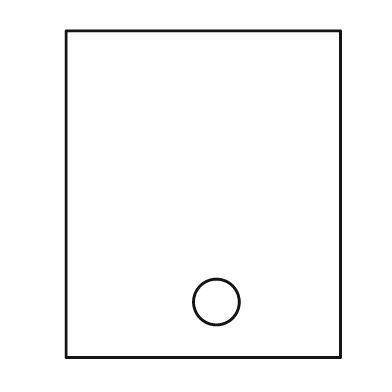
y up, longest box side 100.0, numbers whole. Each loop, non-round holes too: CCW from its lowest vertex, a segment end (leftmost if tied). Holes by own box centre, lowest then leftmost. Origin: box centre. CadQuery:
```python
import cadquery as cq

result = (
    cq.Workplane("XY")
    .moveTo(-42.0, -50.0)
    .lineTo(42.0, -50.0)
    .lineTo(42.0, 50.0)
    .lineTo(-42.0, 50.0)
    .close()
    .moveTo(4.0, -33.0)
    .circle(7.0)
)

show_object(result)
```